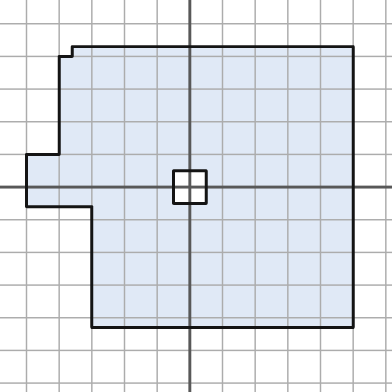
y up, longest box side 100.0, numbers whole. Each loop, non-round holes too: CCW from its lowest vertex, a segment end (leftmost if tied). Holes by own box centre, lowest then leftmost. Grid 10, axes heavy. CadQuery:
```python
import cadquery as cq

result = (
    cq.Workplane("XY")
    .moveTo(-30.0, -43.0)
    .lineTo(50.0, -43.0)
    .lineTo(50.0, 43.0)
    .lineTo(-36.0, 43.0)
    .lineTo(-36.0, 40.0)
    .lineTo(-40.0, 40.0)
    .lineTo(-40.0, 10.0)
    .lineTo(-50.0, 10.0)
    .lineTo(-50.0, -6.0)
    .lineTo(-30.0, -6.0)
    .close()
    .moveTo(-5.0, -5.0)
    .lineTo(5.0, -5.0)
    .lineTo(5.0, 5.0)
    .lineTo(-5.0, 5.0)
    .close()
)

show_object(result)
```